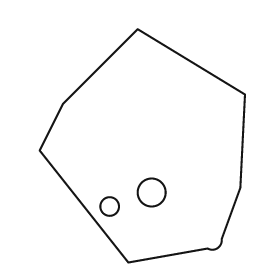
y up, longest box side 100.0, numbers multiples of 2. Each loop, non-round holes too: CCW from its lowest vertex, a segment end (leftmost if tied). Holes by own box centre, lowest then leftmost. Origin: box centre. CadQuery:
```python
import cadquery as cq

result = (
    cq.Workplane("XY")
    .moveTo(-6.0, -50.0)
    .lineTo(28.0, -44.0)
    .threePointArc((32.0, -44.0), (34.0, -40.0))
    .lineTo(42.0, -18.0)
    .lineTo(44.0, 22.0)
    .lineTo(-2.0, 50.0)
    .lineTo(-34.0, 18.0)
    .lineTo(-44.0, -2.0)
    .close()
    .moveTo(-14.0, -26.0)
    .circle(4.0)
    .moveTo(4.0, -20.0)
    .circle(6.0)
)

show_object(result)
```